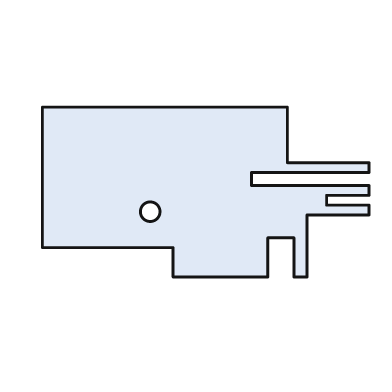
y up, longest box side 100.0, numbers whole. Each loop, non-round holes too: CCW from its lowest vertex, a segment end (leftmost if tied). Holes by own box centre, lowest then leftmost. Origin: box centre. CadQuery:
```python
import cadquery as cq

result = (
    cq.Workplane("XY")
    .moveTo(-10.0, -26.0)
    .lineTo(19.0, -26.0)
    .lineTo(19.0, -14.0)
    .lineTo(27.0, -14.0)
    .lineTo(27.0, -26.0)
    .lineTo(31.0, -26.0)
    .lineTo(31.0, -7.0)
    .lineTo(50.0, -7.0)
    .lineTo(50.0, -4.0)
    .lineTo(37.0, -4.0)
    .lineTo(37.0, -1.0)
    .lineTo(50.0, -1.0)
    .lineTo(50.0, 2.0)
    .lineTo(14.0, 2.0)
    .lineTo(14.0, 6.0)
    .lineTo(50.0, 6.0)
    .lineTo(50.0, 9.0)
    .lineTo(25.0, 9.0)
    .lineTo(25.0, 26.0)
    .lineTo(-50.0, 26.0)
    .lineTo(-50.0, -17.0)
    .lineTo(-10.0, -17.0)
    .close()
    .moveTo(-17.0, -6.0)
    .circle(3.0)
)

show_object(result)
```